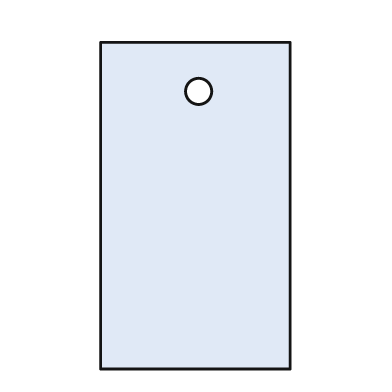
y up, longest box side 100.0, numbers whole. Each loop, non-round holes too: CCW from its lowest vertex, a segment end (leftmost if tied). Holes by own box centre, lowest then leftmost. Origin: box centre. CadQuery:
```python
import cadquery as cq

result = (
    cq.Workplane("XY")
    .moveTo(-29.0, -50.0)
    .lineTo(29.0, -50.0)
    .lineTo(29.0, 50.0)
    .lineTo(-29.0, 50.0)
    .close()
    .moveTo(1.0, 35.0)
    .circle(4.0)
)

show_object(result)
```